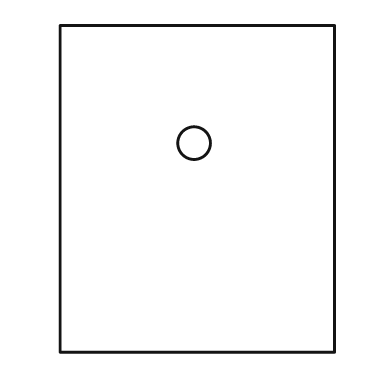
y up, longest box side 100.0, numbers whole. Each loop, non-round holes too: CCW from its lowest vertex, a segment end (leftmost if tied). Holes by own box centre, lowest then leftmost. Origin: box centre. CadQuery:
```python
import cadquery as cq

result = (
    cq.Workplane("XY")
    .moveTo(-42.0, -50.0)
    .lineTo(42.0, -50.0)
    .lineTo(42.0, 50.0)
    .lineTo(-42.0, 50.0)
    .close()
    .moveTo(-1.0, 14.0)
    .circle(5.0)
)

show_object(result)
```